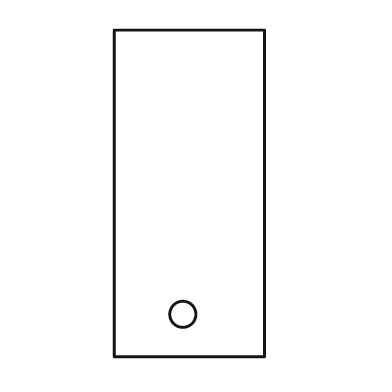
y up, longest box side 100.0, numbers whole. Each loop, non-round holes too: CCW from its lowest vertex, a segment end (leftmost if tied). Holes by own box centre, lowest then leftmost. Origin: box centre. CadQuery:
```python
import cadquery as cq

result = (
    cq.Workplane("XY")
    .moveTo(-23.0, -50.0)
    .lineTo(23.0, -50.0)
    .lineTo(23.0, 50.0)
    .lineTo(-23.0, 50.0)
    .close()
    .moveTo(-2.0, -37.0)
    .circle(4.0)
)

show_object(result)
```